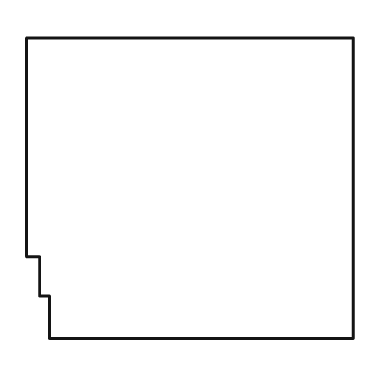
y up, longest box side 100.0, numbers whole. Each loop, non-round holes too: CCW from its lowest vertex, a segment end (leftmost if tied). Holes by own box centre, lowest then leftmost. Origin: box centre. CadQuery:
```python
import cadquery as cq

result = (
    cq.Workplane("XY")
    .moveTo(-43.0, -46.0)
    .lineTo(50.0, -46.0)
    .lineTo(50.0, 46.0)
    .lineTo(-50.0, 46.0)
    .lineTo(-50.0, -21.0)
    .lineTo(-46.0, -21.0)
    .lineTo(-46.0, -33.0)
    .lineTo(-43.0, -33.0)
    .close()
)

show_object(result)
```